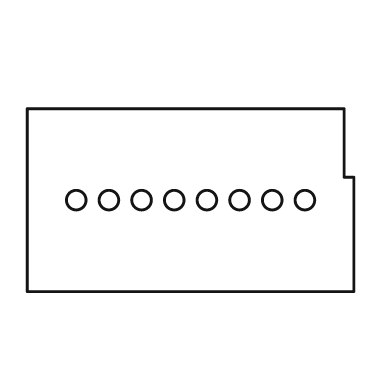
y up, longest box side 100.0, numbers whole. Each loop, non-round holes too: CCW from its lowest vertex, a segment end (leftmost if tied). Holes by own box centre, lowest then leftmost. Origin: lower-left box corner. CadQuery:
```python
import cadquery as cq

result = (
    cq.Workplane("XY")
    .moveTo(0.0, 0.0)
    .lineTo(100.0, 0.0)
    .lineTo(100.0, 35.0)
    .lineTo(97.0, 35.0)
    .lineTo(97.0, 56.0)
    .lineTo(0.0, 56.0)
    .close()
    .moveTo(15.0, 28.0)
    .circle(3.0)
    .moveTo(25.0, 28.0)
    .circle(3.0)
    .moveTo(35.0, 28.0)
    .circle(3.0)
    .moveTo(45.0, 28.0)
    .circle(3.0)
    .moveTo(55.0, 28.0)
    .circle(3.0)
    .moveTo(65.0, 28.0)
    .circle(3.0)
    .moveTo(75.0, 28.0)
    .circle(3.0)
    .moveTo(85.0, 28.0)
    .circle(3.0)
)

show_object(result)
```